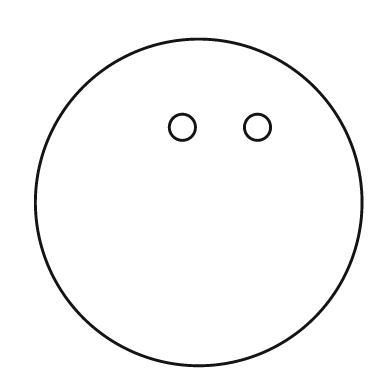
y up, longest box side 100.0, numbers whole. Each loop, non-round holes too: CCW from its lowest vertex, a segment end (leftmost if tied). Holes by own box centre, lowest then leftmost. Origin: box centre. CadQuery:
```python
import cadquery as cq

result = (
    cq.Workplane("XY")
    .moveTo(0.0, 0.0)
    .circle(50.0)
    .moveTo(-5.0, 23.0)
    .circle(4.0)
    .moveTo(18.0, 23.0)
    .circle(4.0)
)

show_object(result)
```